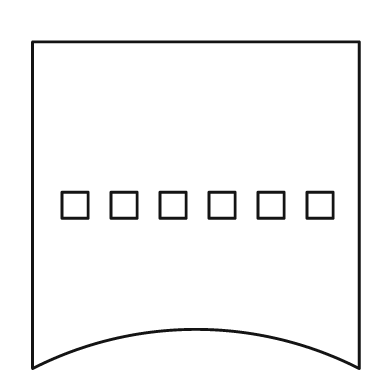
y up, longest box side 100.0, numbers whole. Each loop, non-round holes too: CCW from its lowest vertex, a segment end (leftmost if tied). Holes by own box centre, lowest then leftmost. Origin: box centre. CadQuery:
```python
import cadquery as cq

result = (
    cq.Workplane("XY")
    .moveTo(-50.0, -50.0)
    .threePointArc((0.0, -38.0), (50.0, -50.0))
    .lineTo(50.0, 50.0)
    .lineTo(-50.0, 50.0)
    .close()
    .moveTo(-41.0, -4.0)
    .lineTo(-33.0, -4.0)
    .lineTo(-33.0, 4.0)
    .lineTo(-41.0, 4.0)
    .close()
    .moveTo(-26.0, -4.0)
    .lineTo(-18.0, -4.0)
    .lineTo(-18.0, 4.0)
    .lineTo(-26.0, 4.0)
    .close()
    .moveTo(-11.0, -4.0)
    .lineTo(-3.0, -4.0)
    .lineTo(-3.0, 4.0)
    .lineTo(-11.0, 4.0)
    .close()
    .moveTo(4.0, -4.0)
    .lineTo(12.0, -4.0)
    .lineTo(12.0, 4.0)
    .lineTo(4.0, 4.0)
    .close()
    .moveTo(19.0, -4.0)
    .lineTo(27.0, -4.0)
    .lineTo(27.0, 4.0)
    .lineTo(19.0, 4.0)
    .close()
    .moveTo(34.0, -4.0)
    .lineTo(42.0, -4.0)
    .lineTo(42.0, 4.0)
    .lineTo(34.0, 4.0)
    .close()
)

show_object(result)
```